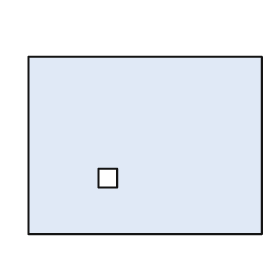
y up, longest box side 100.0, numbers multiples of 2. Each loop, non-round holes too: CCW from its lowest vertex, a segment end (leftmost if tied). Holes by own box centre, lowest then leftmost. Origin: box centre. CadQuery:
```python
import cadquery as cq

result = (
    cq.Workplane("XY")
    .moveTo(-50.0, -38.0)
    .lineTo(50.0, -38.0)
    .lineTo(50.0, 38.0)
    .lineTo(-50.0, 38.0)
    .close()
    .moveTo(-20.0, -18.0)
    .lineTo(-12.0, -18.0)
    .lineTo(-12.0, -10.0)
    .lineTo(-20.0, -10.0)
    .close()
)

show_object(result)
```